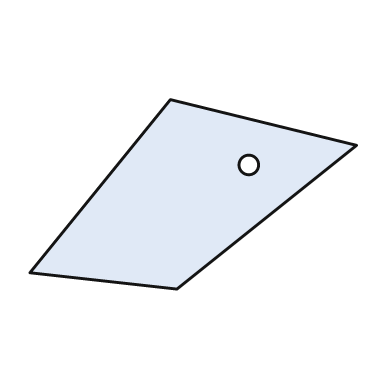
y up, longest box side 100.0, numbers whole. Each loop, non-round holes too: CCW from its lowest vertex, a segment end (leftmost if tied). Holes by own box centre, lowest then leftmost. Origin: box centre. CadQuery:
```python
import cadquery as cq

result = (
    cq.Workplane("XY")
    .moveTo(-5.0, -29.0)
    .lineTo(50.0, 15.0)
    .lineTo(-7.0, 29.0)
    .lineTo(-50.0, -24.0)
    .close()
    .moveTo(17.0, 9.0)
    .circle(3.0)
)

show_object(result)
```